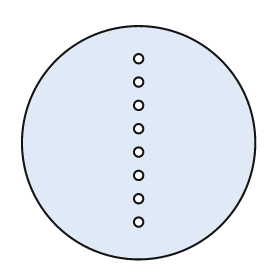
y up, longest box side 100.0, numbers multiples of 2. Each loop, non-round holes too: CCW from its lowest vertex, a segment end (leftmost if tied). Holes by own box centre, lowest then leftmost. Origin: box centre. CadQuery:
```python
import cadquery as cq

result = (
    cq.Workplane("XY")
    .moveTo(0.0, 0.0)
    .circle(50.0)
    .moveTo(0.0, -34.0)
    .circle(2.0)
    .moveTo(0.0, -24.0)
    .circle(2.0)
    .moveTo(0.0, -14.0)
    .circle(2.0)
    .moveTo(0.0, -4.0)
    .circle(2.0)
    .moveTo(0.0, 6.0)
    .circle(2.0)
    .moveTo(0.0, 16.0)
    .circle(2.0)
    .moveTo(0.0, 26.0)
    .circle(2.0)
    .moveTo(0.0, 36.0)
    .circle(2.0)
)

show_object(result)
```